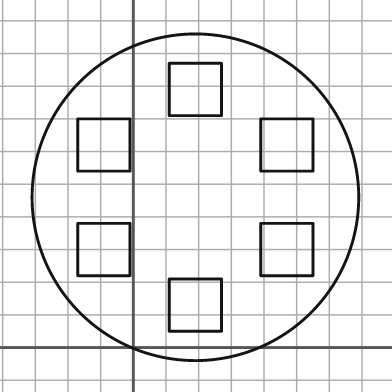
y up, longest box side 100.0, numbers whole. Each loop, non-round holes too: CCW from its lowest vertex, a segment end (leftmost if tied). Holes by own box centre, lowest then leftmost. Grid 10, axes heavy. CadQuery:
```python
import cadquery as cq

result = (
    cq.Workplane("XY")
    .moveTo(19.0, 46.0)
    .circle(50.0)
    .moveTo(11.0, 5.0)
    .lineTo(27.0, 5.0)
    .lineTo(27.0, 21.0)
    .lineTo(11.0, 21.0)
    .close()
    .moveTo(-17.0, 22.0)
    .lineTo(-1.0, 22.0)
    .lineTo(-1.0, 38.0)
    .lineTo(-17.0, 38.0)
    .close()
    .moveTo(39.0, 22.0)
    .lineTo(55.0, 22.0)
    .lineTo(55.0, 38.0)
    .lineTo(39.0, 38.0)
    .close()
    .moveTo(-17.0, 54.0)
    .lineTo(-1.0, 54.0)
    .lineTo(-1.0, 70.0)
    .lineTo(-17.0, 70.0)
    .close()
    .moveTo(39.0, 54.0)
    .lineTo(55.0, 54.0)
    .lineTo(55.0, 70.0)
    .lineTo(39.0, 70.0)
    .close()
    .moveTo(11.0, 71.0)
    .lineTo(27.0, 71.0)
    .lineTo(27.0, 87.0)
    .lineTo(11.0, 87.0)
    .close()
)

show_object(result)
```